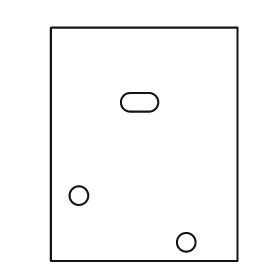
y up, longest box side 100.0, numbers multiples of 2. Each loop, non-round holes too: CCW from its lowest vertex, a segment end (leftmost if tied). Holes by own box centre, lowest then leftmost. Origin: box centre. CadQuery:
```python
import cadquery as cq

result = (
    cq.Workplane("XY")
    .moveTo(-40.0, -50.0)
    .lineTo(40.0, -50.0)
    .lineTo(40.0, 50.0)
    .lineTo(-40.0, 50.0)
    .close()
    .moveTo(18.0, -42.0)
    .circle(4.0)
    .moveTo(-28.0, -22.0)
    .circle(4.0)
    .moveTo(-6.0, 14.0)
    .lineTo(2.0, 14.0)
    .threePointArc((6.0, 18.0), (2.0, 22.0))
    .lineTo(-6.0, 22.0)
    .threePointArc((-10.0, 18.0), (-6.0, 14.0))
    .close()
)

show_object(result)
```